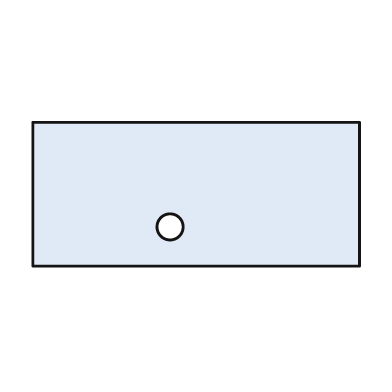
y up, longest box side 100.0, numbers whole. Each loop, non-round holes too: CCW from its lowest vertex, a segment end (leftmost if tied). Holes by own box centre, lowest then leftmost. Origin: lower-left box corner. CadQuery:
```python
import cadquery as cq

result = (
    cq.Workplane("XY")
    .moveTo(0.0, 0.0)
    .lineTo(100.0, 0.0)
    .lineTo(100.0, 44.0)
    .lineTo(0.0, 44.0)
    .close()
    .moveTo(42.0, 12.0)
    .circle(4.0)
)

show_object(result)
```